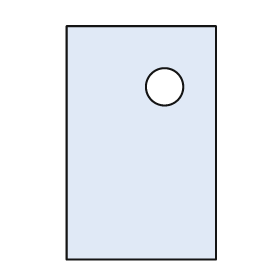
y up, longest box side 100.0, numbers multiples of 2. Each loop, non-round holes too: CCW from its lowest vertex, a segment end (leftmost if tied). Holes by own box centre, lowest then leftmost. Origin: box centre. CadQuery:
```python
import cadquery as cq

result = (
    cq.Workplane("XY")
    .moveTo(-32.0, -50.0)
    .lineTo(32.0, -50.0)
    .lineTo(32.0, 50.0)
    .lineTo(-32.0, 50.0)
    .close()
    .moveTo(10.0, 24.0)
    .circle(8.0)
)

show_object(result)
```